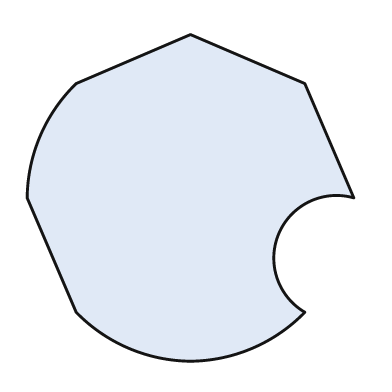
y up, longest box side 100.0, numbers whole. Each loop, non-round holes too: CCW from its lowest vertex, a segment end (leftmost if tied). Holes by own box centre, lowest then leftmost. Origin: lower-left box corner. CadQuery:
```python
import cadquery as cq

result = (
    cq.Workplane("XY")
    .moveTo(50.0, 0.0)
    .threePointArc((69.0, 4.0), (85.0, 15.0))
    .threePointArc((77.0, 39.0), (100.0, 50.0))
    .lineTo(85.0, 85.0)
    .lineTo(50.0, 100.0)
    .lineTo(15.0, 85.0)
    .threePointArc((4.0, 69.0), (0.0, 50.0))
    .lineTo(15.0, 15.0)
    .threePointArc((31.0, 4.0), (50.0, 0.0))
    .close()
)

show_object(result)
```